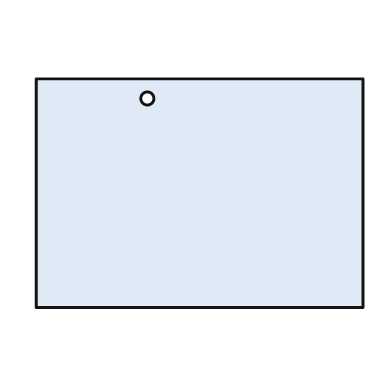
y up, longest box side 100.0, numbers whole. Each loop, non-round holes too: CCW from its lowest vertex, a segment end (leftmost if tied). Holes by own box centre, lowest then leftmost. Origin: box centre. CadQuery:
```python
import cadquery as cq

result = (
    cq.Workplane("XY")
    .moveTo(-50.0, -35.0)
    .lineTo(50.0, -35.0)
    .lineTo(50.0, 35.0)
    .lineTo(-50.0, 35.0)
    .close()
    .moveTo(-16.0, 29.0)
    .circle(2.0)
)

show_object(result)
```